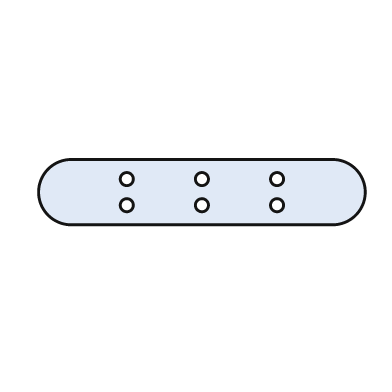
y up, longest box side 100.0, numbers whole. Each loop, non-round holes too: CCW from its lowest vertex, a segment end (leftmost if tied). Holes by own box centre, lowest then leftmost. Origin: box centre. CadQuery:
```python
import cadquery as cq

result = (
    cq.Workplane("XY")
    .moveTo(-40.0, -10.0)
    .lineTo(40.0, -10.0)
    .threePointArc((50.0, 0.0), (40.0, 10.0))
    .lineTo(-40.0, 10.0)
    .threePointArc((-50.0, 0.0), (-40.0, -10.0))
    .close()
    .moveTo(-23.0, -4.0)
    .circle(2.0)
    .moveTo(0.0, -4.0)
    .circle(2.0)
    .moveTo(23.0, -4.0)
    .circle(2.0)
    .moveTo(-23.0, 4.0)
    .circle(2.0)
    .moveTo(0.0, 4.0)
    .circle(2.0)
    .moveTo(23.0, 4.0)
    .circle(2.0)
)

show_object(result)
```